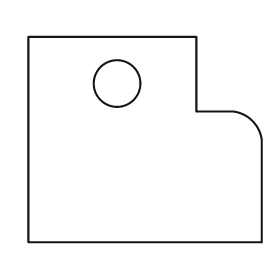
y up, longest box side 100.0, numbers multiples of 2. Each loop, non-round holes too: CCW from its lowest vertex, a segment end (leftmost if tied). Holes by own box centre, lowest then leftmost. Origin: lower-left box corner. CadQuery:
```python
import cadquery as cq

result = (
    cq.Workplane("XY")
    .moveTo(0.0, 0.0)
    .lineTo(100.0, 0.0)
    .lineTo(100.0, 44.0)
    .threePointArc((96.0, 52.0), (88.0, 56.0))
    .lineTo(72.0, 56.0)
    .lineTo(72.0, 88.0)
    .lineTo(0.0, 88.0)
    .close()
    .moveTo(38.0, 68.0)
    .circle(10.0)
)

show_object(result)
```